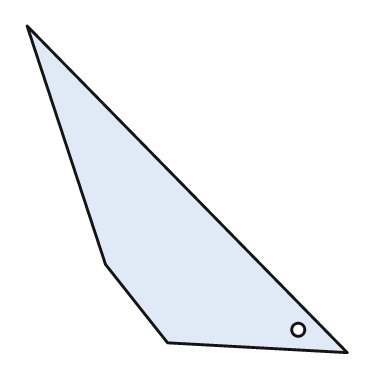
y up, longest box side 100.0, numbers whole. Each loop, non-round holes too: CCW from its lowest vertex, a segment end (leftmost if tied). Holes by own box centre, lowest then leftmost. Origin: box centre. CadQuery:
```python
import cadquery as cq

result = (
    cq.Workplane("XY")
    .moveTo(49.0, -50.0)
    .lineTo(-49.0, 50.0)
    .lineTo(-25.0, -23.0)
    .lineTo(-6.0, -47.0)
    .close()
    .moveTo(34.0, -43.0)
    .circle(2.0)
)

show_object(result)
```